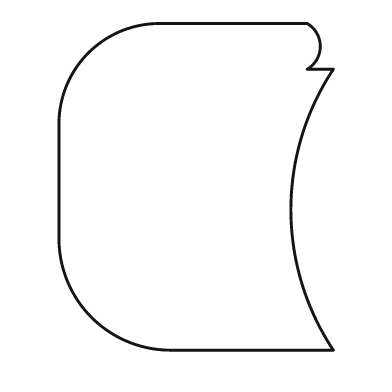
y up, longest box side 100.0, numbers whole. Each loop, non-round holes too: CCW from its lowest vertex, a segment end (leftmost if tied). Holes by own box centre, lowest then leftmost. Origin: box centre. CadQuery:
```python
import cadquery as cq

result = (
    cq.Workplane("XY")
    .moveTo(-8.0, -50.0)
    .lineTo(42.0, -50.0)
    .threePointArc((29.0, -7.0), (42.0, 36.0))
    .lineTo(34.0, 36.0)
    .threePointArc((38.0, 43.0), (34.0, 50.0))
    .lineTo(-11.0, 50.0)
    .threePointArc((-33.0, 41.0), (-42.0, 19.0))
    .lineTo(-42.0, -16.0)
    .threePointArc((-32.0, -40.0), (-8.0, -50.0))
    .close()
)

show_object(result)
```